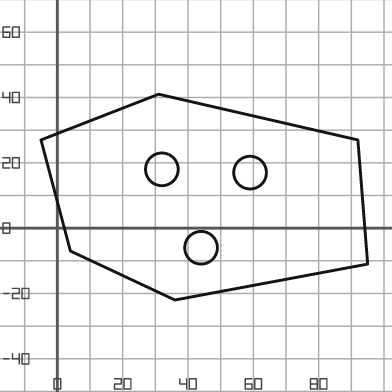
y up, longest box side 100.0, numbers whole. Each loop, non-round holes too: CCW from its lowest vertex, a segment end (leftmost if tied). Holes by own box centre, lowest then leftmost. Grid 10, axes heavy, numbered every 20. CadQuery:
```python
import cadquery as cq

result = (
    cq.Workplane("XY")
    .moveTo(36.0, -22.0)
    .lineTo(95.0, -11.0)
    .lineTo(92.0, 27.0)
    .lineTo(31.0, 41.0)
    .lineTo(-5.0, 27.0)
    .lineTo(4.0, -7.0)
    .close()
    .moveTo(44.0, -6.0)
    .circle(5.0)
    .moveTo(59.0, 17.0)
    .circle(5.0)
    .moveTo(32.0, 18.0)
    .circle(5.0)
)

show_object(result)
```